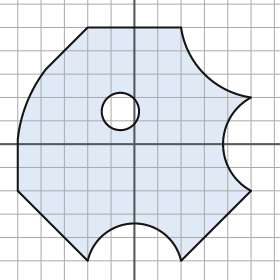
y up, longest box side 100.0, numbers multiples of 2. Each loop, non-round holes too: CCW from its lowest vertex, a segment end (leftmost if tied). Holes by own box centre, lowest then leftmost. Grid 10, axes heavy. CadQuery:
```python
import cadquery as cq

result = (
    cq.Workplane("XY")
    .moveTo(-20.0, -50.0)
    .threePointArc((0.0, -34.0), (20.0, -50.0))
    .lineTo(50.0, -20.0)
    .threePointArc((38.0, 0.0), (50.0, 20.0))
    .threePointArc((30.0, 30.0), (20.0, 50.0))
    .lineTo(-20.0, 50.0)
    .lineTo(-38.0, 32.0)
    .threePointArc((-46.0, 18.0), (-50.0, 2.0))
    .lineTo(-50.0, -20.0)
    .close()
    .moveTo(-6.0, 14.0)
    .circle(8.0)
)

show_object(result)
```